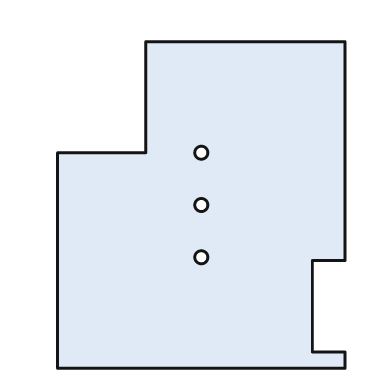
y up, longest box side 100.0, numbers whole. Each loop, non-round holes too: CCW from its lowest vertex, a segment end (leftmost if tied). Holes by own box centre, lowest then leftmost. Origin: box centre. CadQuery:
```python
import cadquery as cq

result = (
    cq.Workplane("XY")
    .moveTo(-44.0, -50.0)
    .lineTo(44.0, -50.0)
    .lineTo(44.0, -45.0)
    .lineTo(34.0, -45.0)
    .lineTo(34.0, -17.0)
    .lineTo(44.0, -17.0)
    .lineTo(44.0, 50.0)
    .lineTo(-17.0, 50.0)
    .lineTo(-17.0, 16.0)
    .lineTo(-44.0, 16.0)
    .close()
    .moveTo(0.0, -16.0)
    .circle(2.0)
    .moveTo(0.0, 0.0)
    .circle(2.0)
    .moveTo(0.0, 16.0)
    .circle(2.0)
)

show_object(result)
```